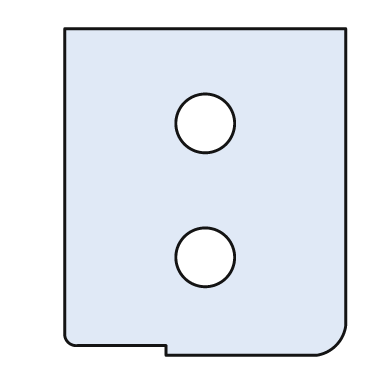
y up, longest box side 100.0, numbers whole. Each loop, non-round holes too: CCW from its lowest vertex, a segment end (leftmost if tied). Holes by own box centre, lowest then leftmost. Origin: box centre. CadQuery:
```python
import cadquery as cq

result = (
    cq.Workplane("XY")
    .moveTo(-12.0, -50.0)
    .lineTo(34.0, -50.0)
    .threePointArc((40.0, -47.0), (43.0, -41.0))
    .lineTo(43.0, 50.0)
    .lineTo(-43.0, 50.0)
    .lineTo(-43.0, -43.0)
    .threePointArc((-42.0, -46.0), (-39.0, -47.0))
    .lineTo(-12.0, -47.0)
    .close()
    .moveTo(0.0, -20.0)
    .circle(9.0)
    .moveTo(0.0, 21.0)
    .circle(9.0)
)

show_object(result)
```